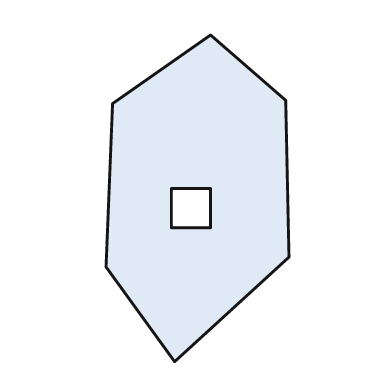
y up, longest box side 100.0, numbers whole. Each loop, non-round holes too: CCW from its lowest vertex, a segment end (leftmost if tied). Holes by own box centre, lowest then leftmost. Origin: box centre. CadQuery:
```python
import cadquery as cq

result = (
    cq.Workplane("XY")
    .moveTo(-7.0, -50.0)
    .lineTo(28.0, -18.0)
    .lineTo(27.0, 30.0)
    .lineTo(4.0, 50.0)
    .lineTo(-26.0, 29.0)
    .lineTo(-28.0, -21.0)
    .close()
    .moveTo(-8.0, -9.0)
    .lineTo(4.0, -9.0)
    .lineTo(4.0, 3.0)
    .lineTo(-8.0, 3.0)
    .close()
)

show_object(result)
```